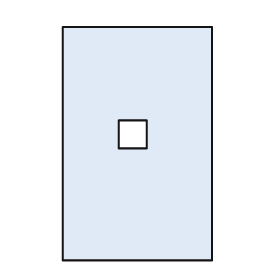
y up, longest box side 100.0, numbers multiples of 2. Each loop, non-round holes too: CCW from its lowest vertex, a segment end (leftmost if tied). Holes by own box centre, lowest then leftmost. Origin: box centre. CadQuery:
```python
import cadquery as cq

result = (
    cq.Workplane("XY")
    .moveTo(-32.0, -50.0)
    .lineTo(32.0, -50.0)
    .lineTo(32.0, 50.0)
    .lineTo(-32.0, 50.0)
    .close()
    .moveTo(-8.0, -2.0)
    .lineTo(4.0, -2.0)
    .lineTo(4.0, 10.0)
    .lineTo(-8.0, 10.0)
    .close()
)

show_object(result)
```